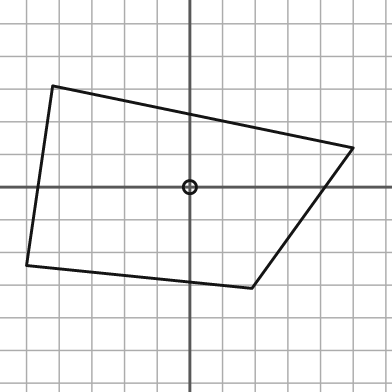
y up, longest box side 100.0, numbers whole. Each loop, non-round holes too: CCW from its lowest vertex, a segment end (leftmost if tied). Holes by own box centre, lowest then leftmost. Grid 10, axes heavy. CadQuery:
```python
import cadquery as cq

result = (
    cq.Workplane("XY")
    .moveTo(19.0, -31.0)
    .lineTo(50.0, 12.0)
    .lineTo(-42.0, 31.0)
    .lineTo(-50.0, -24.0)
    .close()
    .moveTo(0.0, 0.0)
    .circle(2.0)
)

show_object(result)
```